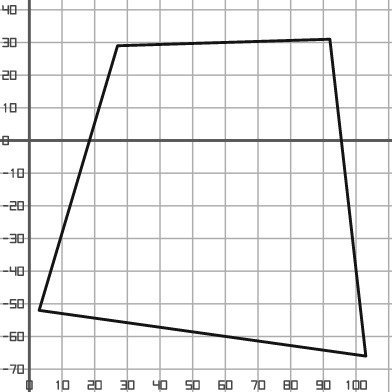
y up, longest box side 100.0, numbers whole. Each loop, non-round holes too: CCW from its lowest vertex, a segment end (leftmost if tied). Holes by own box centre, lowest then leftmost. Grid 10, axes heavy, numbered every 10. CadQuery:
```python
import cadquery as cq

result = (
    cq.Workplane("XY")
    .moveTo(103.0, -66.0)
    .lineTo(92.0, 31.0)
    .lineTo(27.0, 29.0)
    .lineTo(3.0, -52.0)
    .close()
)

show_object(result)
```